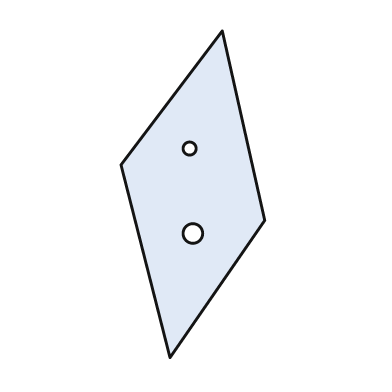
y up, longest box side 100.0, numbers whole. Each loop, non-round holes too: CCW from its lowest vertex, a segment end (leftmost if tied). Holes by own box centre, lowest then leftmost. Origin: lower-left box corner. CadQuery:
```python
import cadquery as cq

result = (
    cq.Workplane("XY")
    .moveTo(15.0, 0.0)
    .lineTo(44.0, 42.0)
    .lineTo(31.0, 100.0)
    .lineTo(0.0, 59.0)
    .close()
    .moveTo(22.0, 38.0)
    .circle(3.0)
    .moveTo(21.0, 64.0)
    .circle(2.0)
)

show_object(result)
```